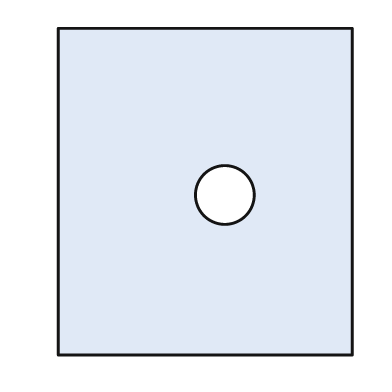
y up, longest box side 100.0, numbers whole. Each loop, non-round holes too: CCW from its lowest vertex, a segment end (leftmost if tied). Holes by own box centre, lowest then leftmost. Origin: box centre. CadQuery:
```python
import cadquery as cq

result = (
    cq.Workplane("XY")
    .moveTo(-45.0, -50.0)
    .lineTo(45.0, -50.0)
    .lineTo(45.0, 50.0)
    .lineTo(-45.0, 50.0)
    .close()
    .moveTo(6.0, -1.0)
    .circle(9.0)
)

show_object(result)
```